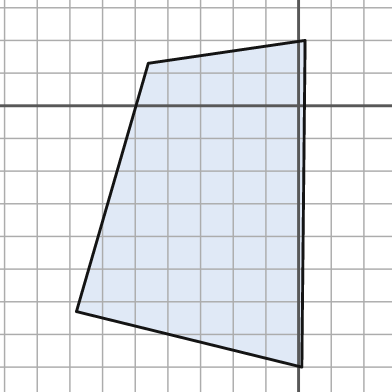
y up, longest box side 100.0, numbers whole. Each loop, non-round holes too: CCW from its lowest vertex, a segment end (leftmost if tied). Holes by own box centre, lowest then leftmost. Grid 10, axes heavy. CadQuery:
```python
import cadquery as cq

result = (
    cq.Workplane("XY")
    .moveTo(1.0, -80.0)
    .lineTo(2.0, 20.0)
    .lineTo(-46.0, 13.0)
    .lineTo(-68.0, -63.0)
    .close()
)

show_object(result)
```